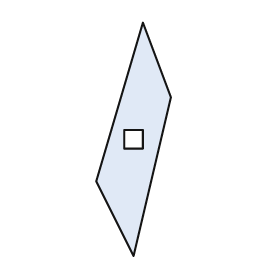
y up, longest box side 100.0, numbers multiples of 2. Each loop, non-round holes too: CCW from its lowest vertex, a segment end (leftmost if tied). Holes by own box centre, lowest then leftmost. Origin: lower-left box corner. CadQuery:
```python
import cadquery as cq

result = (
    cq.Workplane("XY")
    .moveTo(16.0, 0.0)
    .lineTo(32.0, 68.0)
    .lineTo(20.0, 100.0)
    .lineTo(0.0, 32.0)
    .close()
    .moveTo(12.0, 46.0)
    .lineTo(20.0, 46.0)
    .lineTo(20.0, 54.0)
    .lineTo(12.0, 54.0)
    .close()
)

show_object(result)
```